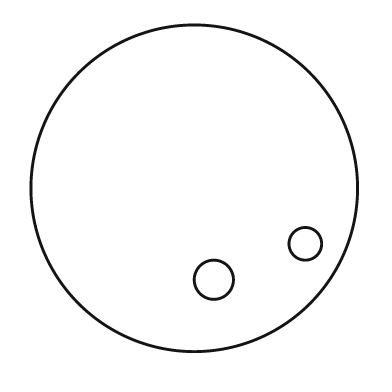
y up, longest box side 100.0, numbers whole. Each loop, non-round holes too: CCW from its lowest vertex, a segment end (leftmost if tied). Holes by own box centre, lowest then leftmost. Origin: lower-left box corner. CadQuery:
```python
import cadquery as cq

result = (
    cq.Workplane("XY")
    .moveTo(50.0, 50.0)
    .circle(50.0)
    .moveTo(56.0, 22.0)
    .circle(6.0)
    .moveTo(84.0, 33.0)
    .circle(5.0)
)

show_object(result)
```